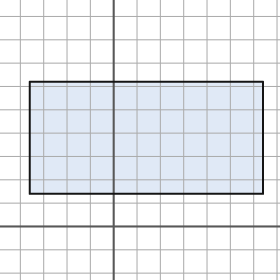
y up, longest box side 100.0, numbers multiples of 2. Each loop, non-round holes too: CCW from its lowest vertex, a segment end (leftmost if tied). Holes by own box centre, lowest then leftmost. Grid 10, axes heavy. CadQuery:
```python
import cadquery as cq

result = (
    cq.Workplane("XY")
    .moveTo(-36.0, 14.0)
    .lineTo(64.0, 14.0)
    .lineTo(64.0, 62.0)
    .lineTo(-36.0, 62.0)
    .close()
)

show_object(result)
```